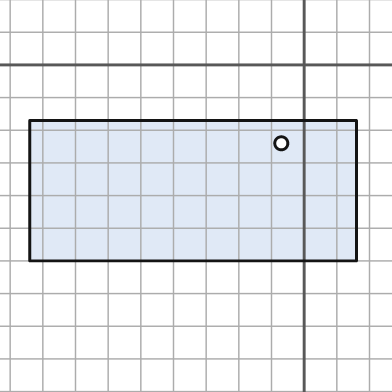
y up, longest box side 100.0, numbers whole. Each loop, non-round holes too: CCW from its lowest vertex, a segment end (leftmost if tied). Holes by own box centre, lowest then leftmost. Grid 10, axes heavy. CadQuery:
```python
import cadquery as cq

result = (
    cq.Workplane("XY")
    .moveTo(-84.0, -60.0)
    .lineTo(16.0, -60.0)
    .lineTo(16.0, -17.0)
    .lineTo(-84.0, -17.0)
    .close()
    .moveTo(-7.0, -24.0)
    .circle(2.0)
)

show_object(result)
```